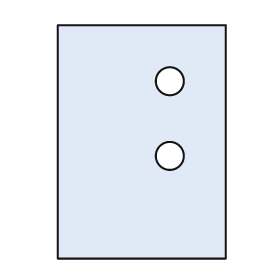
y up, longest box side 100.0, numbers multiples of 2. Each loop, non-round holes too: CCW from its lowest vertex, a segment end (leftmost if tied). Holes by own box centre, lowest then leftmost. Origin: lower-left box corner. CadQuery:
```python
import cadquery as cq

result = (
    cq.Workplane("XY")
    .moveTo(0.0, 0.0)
    .lineTo(72.0, 0.0)
    .lineTo(72.0, 100.0)
    .lineTo(0.0, 100.0)
    .close()
    .moveTo(48.0, 44.0)
    .circle(6.0)
    .moveTo(48.0, 76.0)
    .circle(6.0)
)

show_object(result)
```